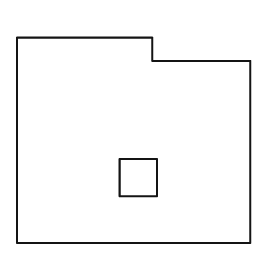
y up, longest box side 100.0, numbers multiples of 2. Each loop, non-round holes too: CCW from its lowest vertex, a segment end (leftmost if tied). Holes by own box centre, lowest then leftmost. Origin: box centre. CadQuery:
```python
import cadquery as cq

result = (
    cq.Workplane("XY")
    .moveTo(-50.0, -44.0)
    .lineTo(50.0, -44.0)
    .lineTo(50.0, 34.0)
    .lineTo(8.0, 34.0)
    .lineTo(8.0, 44.0)
    .lineTo(-50.0, 44.0)
    .close()
    .moveTo(-6.0, -24.0)
    .lineTo(10.0, -24.0)
    .lineTo(10.0, -8.0)
    .lineTo(-6.0, -8.0)
    .close()
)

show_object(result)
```